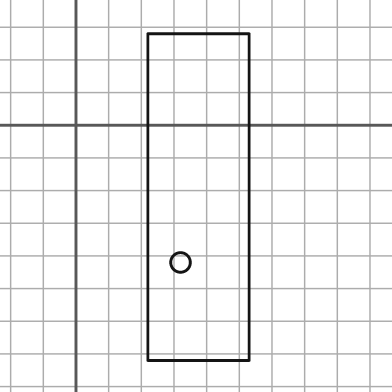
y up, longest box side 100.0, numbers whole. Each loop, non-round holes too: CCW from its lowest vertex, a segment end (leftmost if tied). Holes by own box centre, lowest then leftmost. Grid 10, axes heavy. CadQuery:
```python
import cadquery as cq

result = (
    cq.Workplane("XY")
    .moveTo(22.0, -72.0)
    .lineTo(53.0, -72.0)
    .lineTo(53.0, 28.0)
    .lineTo(22.0, 28.0)
    .close()
    .moveTo(32.0, -42.0)
    .circle(3.0)
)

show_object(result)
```